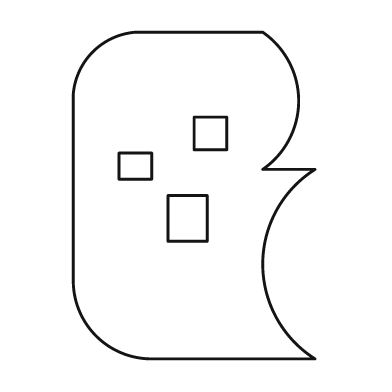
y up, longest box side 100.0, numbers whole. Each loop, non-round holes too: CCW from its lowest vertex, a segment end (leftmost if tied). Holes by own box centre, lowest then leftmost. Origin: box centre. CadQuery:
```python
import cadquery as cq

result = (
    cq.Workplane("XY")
    .moveTo(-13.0, -50.0)
    .lineTo(37.0, -50.0)
    .threePointArc((21.0, -21.0), (37.0, 8.0))
    .lineTo(21.0, 8.0)
    .threePointArc((32.0, 29.0), (21.0, 50.0))
    .lineTo(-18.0, 50.0)
    .threePointArc((-31.0, 44.0), (-37.0, 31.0))
    .lineTo(-37.0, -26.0)
    .threePointArc((-30.0, -43.0), (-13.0, -50.0))
    .close()
    .moveTo(-8.0, -14.0)
    .lineTo(4.0, -14.0)
    .lineTo(4.0, 0.0)
    .lineTo(-8.0, 0.0)
    .close()
    .moveTo(-23.0, 5.0)
    .lineTo(-13.0, 5.0)
    .lineTo(-13.0, 13.0)
    .lineTo(-23.0, 13.0)
    .close()
    .moveTo(0.0, 14.0)
    .lineTo(10.0, 14.0)
    .lineTo(10.0, 24.0)
    .lineTo(0.0, 24.0)
    .close()
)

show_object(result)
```